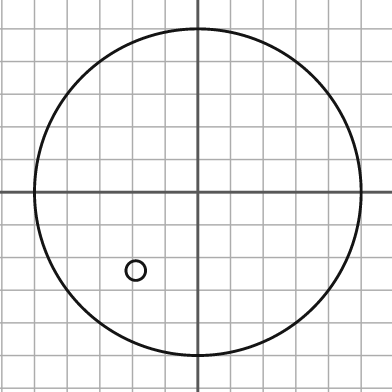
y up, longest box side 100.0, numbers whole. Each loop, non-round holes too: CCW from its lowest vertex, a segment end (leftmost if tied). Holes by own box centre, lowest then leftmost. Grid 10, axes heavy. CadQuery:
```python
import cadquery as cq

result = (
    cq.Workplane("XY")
    .moveTo(0.0, 0.0)
    .circle(50.0)
    .moveTo(-19.0, -24.0)
    .circle(3.0)
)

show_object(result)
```